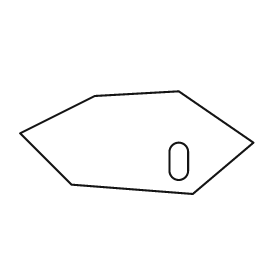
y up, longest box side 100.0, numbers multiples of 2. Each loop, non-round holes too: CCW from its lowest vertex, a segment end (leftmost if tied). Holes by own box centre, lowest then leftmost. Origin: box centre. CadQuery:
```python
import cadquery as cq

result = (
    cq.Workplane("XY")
    .moveTo(24.0, -22.0)
    .lineTo(50.0, 0.0)
    .lineTo(18.0, 22.0)
    .lineTo(-18.0, 20.0)
    .lineTo(-50.0, 4.0)
    .lineTo(-28.0, -18.0)
    .close()
    .moveTo(14.0, -12.0)
    .threePointArc((18.0, -16.0), (22.0, -12.0))
    .lineTo(22.0, -4.0)
    .threePointArc((18.0, 0.0), (14.0, -4.0))
    .close()
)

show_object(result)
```